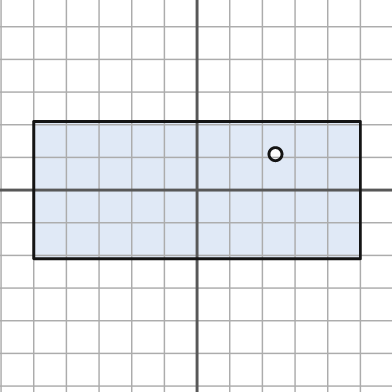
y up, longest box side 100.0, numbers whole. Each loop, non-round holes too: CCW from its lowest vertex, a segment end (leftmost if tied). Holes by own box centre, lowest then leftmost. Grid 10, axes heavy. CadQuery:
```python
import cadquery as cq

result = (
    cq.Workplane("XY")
    .moveTo(-50.0, -21.0)
    .lineTo(50.0, -21.0)
    .lineTo(50.0, 21.0)
    .lineTo(-50.0, 21.0)
    .close()
    .moveTo(24.0, 11.0)
    .circle(2.0)
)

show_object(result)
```